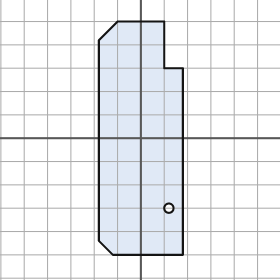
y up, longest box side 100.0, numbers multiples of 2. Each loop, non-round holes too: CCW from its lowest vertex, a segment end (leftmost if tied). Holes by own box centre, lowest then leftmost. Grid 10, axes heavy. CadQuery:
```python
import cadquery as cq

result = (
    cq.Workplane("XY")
    .moveTo(-12.0, -50.0)
    .lineTo(18.0, -50.0)
    .lineTo(18.0, 30.0)
    .lineTo(10.0, 30.0)
    .lineTo(10.0, 50.0)
    .lineTo(-10.0, 50.0)
    .lineTo(-18.0, 42.0)
    .lineTo(-18.0, -44.0)
    .close()
    .moveTo(12.0, -30.0)
    .circle(2.0)
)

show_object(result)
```